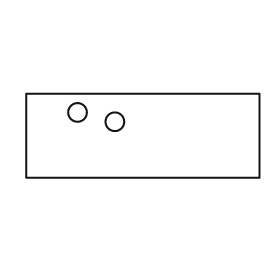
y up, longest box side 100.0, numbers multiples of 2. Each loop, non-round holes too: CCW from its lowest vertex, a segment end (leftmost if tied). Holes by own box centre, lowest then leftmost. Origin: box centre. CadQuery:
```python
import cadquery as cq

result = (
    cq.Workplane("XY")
    .moveTo(-50.0, -18.0)
    .lineTo(50.0, -18.0)
    .lineTo(50.0, 18.0)
    .lineTo(-50.0, 18.0)
    .close()
    .moveTo(-12.0, 6.0)
    .circle(4.0)
    .moveTo(-28.0, 10.0)
    .circle(4.0)
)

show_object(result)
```